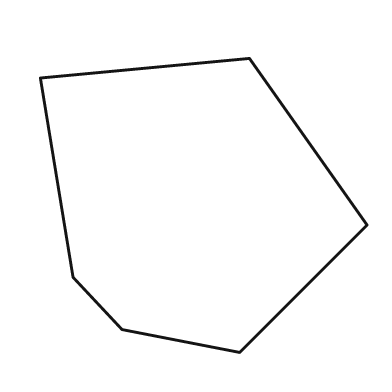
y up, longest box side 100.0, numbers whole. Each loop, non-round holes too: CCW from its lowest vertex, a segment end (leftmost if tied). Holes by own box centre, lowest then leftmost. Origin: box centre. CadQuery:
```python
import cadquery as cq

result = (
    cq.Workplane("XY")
    .moveTo(11.0, -45.0)
    .lineTo(50.0, -6.0)
    .lineTo(14.0, 45.0)
    .lineTo(-50.0, 39.0)
    .lineTo(-40.0, -22.0)
    .lineTo(-25.0, -38.0)
    .close()
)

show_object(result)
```